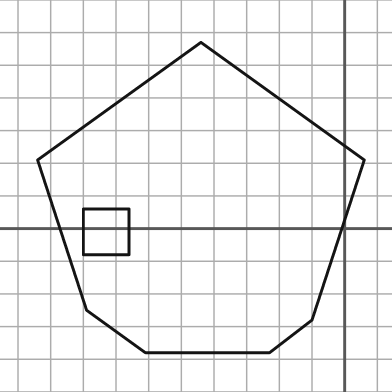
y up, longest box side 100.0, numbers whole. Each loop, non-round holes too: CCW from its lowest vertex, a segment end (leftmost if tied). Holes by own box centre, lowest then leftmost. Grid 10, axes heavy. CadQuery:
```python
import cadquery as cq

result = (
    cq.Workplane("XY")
    .moveTo(-61.0, -38.0)
    .lineTo(-23.0, -38.0)
    .lineTo(-10.0, -28.0)
    .lineTo(6.0, 21.0)
    .lineTo(-44.0, 57.0)
    .lineTo(-94.0, 21.0)
    .lineTo(-79.0, -25.0)
    .close()
    .moveTo(-80.0, -8.0)
    .lineTo(-66.0, -8.0)
    .lineTo(-66.0, 6.0)
    .lineTo(-80.0, 6.0)
    .close()
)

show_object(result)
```